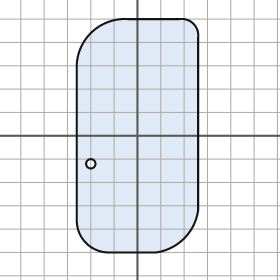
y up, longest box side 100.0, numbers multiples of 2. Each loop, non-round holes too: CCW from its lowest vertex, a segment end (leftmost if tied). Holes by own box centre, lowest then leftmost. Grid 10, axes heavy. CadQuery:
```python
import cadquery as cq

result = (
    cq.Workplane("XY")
    .moveTo(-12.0, -50.0)
    .lineTo(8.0, -50.0)
    .threePointArc((20.0, -44.0), (26.0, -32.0))
    .lineTo(26.0, 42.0)
    .threePointArc((24.0, 48.0), (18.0, 50.0))
    .lineTo(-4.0, 50.0)
    .threePointArc((-20.0, 44.0), (-26.0, 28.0))
    .lineTo(-26.0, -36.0)
    .threePointArc((-22.0, -46.0), (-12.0, -50.0))
    .close()
    .moveTo(-20.0, -12.0)
    .circle(2.0)
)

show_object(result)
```